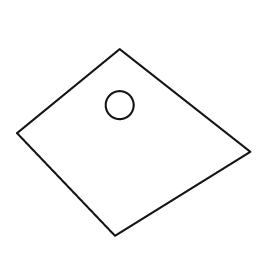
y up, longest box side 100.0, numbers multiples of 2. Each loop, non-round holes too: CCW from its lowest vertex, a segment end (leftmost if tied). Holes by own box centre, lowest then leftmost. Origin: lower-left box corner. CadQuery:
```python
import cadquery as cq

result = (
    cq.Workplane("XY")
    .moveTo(42.0, 0.0)
    .lineTo(100.0, 36.0)
    .lineTo(44.0, 80.0)
    .lineTo(0.0, 44.0)
    .close()
    .moveTo(44.0, 56.0)
    .circle(6.0)
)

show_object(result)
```